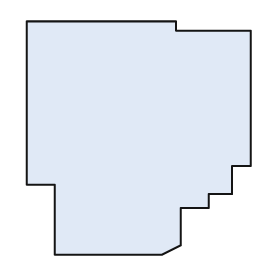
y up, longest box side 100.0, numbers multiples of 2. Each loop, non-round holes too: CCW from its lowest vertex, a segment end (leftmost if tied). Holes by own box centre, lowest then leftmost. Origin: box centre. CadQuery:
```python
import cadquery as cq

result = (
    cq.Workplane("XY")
    .moveTo(-36.0, -50.0)
    .lineTo(10.0, -50.0)
    .lineTo(18.0, -46.0)
    .lineTo(18.0, -30.0)
    .lineTo(30.0, -30.0)
    .lineTo(30.0, -24.0)
    .lineTo(40.0, -24.0)
    .lineTo(40.0, -12.0)
    .lineTo(48.0, -12.0)
    .lineTo(48.0, 46.0)
    .lineTo(16.0, 46.0)
    .lineTo(16.0, 50.0)
    .lineTo(-48.0, 50.0)
    .lineTo(-48.0, -20.0)
    .lineTo(-36.0, -20.0)
    .close()
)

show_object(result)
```